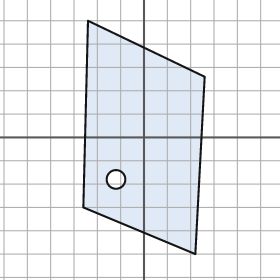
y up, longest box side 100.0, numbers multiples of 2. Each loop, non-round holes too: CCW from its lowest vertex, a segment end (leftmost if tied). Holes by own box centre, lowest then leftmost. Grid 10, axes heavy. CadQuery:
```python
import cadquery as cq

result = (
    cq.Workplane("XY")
    .moveTo(22.0, -50.0)
    .lineTo(26.0, 26.0)
    .lineTo(-24.0, 50.0)
    .lineTo(-26.0, -30.0)
    .close()
    .moveTo(-12.0, -18.0)
    .circle(4.0)
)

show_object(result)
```